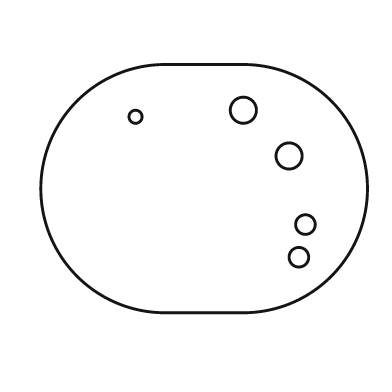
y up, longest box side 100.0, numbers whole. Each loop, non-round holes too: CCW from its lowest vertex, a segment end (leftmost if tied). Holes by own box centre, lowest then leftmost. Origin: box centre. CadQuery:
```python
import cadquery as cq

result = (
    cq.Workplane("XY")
    .moveTo(-12.0, -38.0)
    .lineTo(12.0, -38.0)
    .threePointArc((50.0, 0.0), (12.0, 38.0))
    .lineTo(-12.0, 38.0)
    .threePointArc((-50.0, 0.0), (-12.0, -38.0))
    .close()
    .moveTo(29.0, -21.0)
    .circle(3.0)
    .moveTo(31.0, -11.0)
    .circle(3.0)
    .moveTo(26.0, 10.0)
    .circle(4.0)
    .moveTo(-21.0, 22.0)
    .circle(2.0)
    .moveTo(12.0, 24.0)
    .circle(4.0)
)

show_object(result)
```